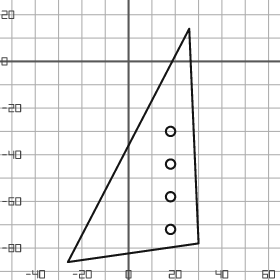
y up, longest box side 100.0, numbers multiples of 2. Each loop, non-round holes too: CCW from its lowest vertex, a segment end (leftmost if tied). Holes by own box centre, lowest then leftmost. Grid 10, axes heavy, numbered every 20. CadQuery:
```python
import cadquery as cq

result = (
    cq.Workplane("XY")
    .moveTo(-26.0, -86.0)
    .lineTo(30.0, -78.0)
    .lineTo(26.0, 14.0)
    .close()
    .moveTo(18.0, -72.0)
    .circle(2.0)
    .moveTo(18.0, -58.0)
    .circle(2.0)
    .moveTo(18.0, -44.0)
    .circle(2.0)
    .moveTo(18.0, -30.0)
    .circle(2.0)
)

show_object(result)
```